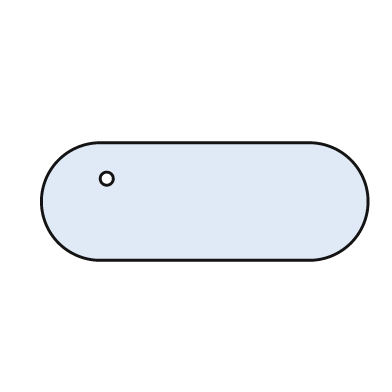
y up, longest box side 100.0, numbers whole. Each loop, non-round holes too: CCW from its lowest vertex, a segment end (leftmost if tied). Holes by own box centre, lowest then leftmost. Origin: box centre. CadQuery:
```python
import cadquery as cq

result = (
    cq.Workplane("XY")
    .moveTo(-32.0, -18.0)
    .lineTo(32.0, -18.0)
    .threePointArc((50.0, 0.0), (32.0, 18.0))
    .lineTo(-32.0, 18.0)
    .threePointArc((-50.0, 0.0), (-32.0, -18.0))
    .close()
    .moveTo(-30.0, 7.0)
    .circle(2.0)
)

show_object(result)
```